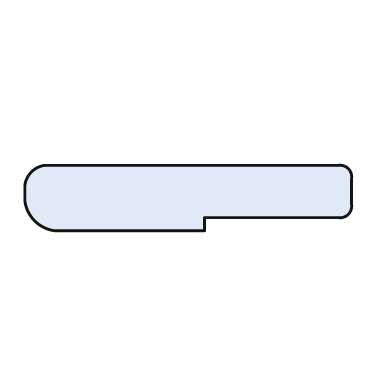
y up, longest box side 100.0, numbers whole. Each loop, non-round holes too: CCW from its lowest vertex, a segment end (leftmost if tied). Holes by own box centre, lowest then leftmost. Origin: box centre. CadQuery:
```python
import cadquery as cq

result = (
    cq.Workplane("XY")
    .moveTo(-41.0, -10.0)
    .lineTo(5.0, -10.0)
    .lineTo(5.0, -6.0)
    .lineTo(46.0, -6.0)
    .threePointArc((49.0, -5.0), (50.0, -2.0))
    .lineTo(50.0, 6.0)
    .threePointArc((49.0, 9.0), (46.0, 10.0))
    .lineTo(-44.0, 10.0)
    .threePointArc((-48.0, 8.0), (-50.0, 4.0))
    .lineTo(-50.0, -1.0)
    .threePointArc((-47.0, -7.0), (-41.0, -10.0))
    .close()
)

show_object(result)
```